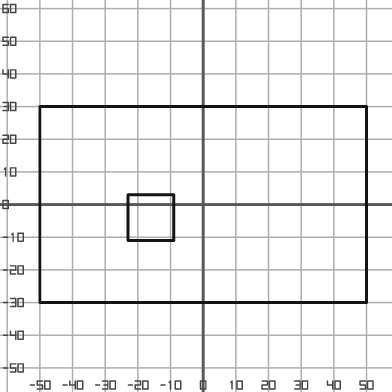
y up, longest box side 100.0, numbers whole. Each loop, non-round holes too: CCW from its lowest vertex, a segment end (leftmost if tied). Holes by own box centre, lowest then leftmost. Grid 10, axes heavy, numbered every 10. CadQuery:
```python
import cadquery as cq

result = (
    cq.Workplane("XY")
    .moveTo(-50.0, -30.0)
    .lineTo(50.0, -30.0)
    .lineTo(50.0, 30.0)
    .lineTo(-50.0, 30.0)
    .close()
    .moveTo(-23.0, -11.0)
    .lineTo(-9.0, -11.0)
    .lineTo(-9.0, 3.0)
    .lineTo(-23.0, 3.0)
    .close()
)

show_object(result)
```